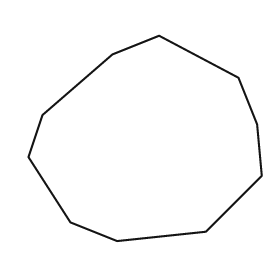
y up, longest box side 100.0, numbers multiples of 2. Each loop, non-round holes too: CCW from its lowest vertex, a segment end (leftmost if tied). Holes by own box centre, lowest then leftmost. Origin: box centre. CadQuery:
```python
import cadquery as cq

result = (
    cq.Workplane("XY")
    .moveTo(-12.0, -44.0)
    .lineTo(26.0, -40.0)
    .lineTo(50.0, -16.0)
    .lineTo(48.0, 6.0)
    .lineTo(40.0, 26.0)
    .lineTo(6.0, 44.0)
    .lineTo(-14.0, 36.0)
    .lineTo(-44.0, 10.0)
    .lineTo(-50.0, -8.0)
    .lineTo(-32.0, -36.0)
    .close()
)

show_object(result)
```